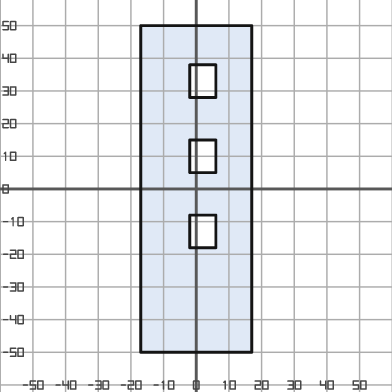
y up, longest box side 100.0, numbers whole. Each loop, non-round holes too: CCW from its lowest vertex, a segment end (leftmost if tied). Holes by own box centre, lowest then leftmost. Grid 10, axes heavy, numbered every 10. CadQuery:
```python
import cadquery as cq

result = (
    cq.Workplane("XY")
    .moveTo(-17.0, -50.0)
    .lineTo(17.0, -50.0)
    .lineTo(17.0, 50.0)
    .lineTo(-17.0, 50.0)
    .close()
    .moveTo(-2.0, -18.0)
    .lineTo(6.0, -18.0)
    .lineTo(6.0, -8.0)
    .lineTo(-2.0, -8.0)
    .close()
    .moveTo(-2.0, 5.0)
    .lineTo(6.0, 5.0)
    .lineTo(6.0, 15.0)
    .lineTo(-2.0, 15.0)
    .close()
    .moveTo(-2.0, 28.0)
    .lineTo(6.0, 28.0)
    .lineTo(6.0, 38.0)
    .lineTo(-2.0, 38.0)
    .close()
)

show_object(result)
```